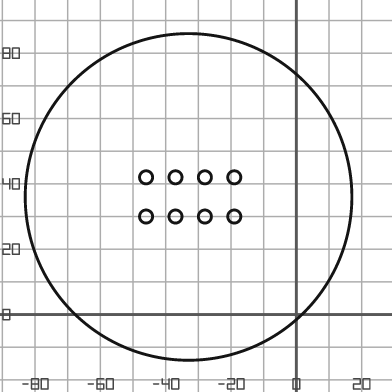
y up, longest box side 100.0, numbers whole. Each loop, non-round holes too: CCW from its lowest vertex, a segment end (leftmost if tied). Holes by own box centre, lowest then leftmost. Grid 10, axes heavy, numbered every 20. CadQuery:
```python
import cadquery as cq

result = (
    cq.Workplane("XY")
    .moveTo(-33.0, 36.0)
    .circle(50.0)
    .moveTo(-46.0, 30.0)
    .circle(2.0)
    .moveTo(-37.0, 30.0)
    .circle(2.0)
    .moveTo(-28.0, 30.0)
    .circle(2.0)
    .moveTo(-19.0, 30.0)
    .circle(2.0)
    .moveTo(-46.0, 42.0)
    .circle(2.0)
    .moveTo(-37.0, 42.0)
    .circle(2.0)
    .moveTo(-28.0, 42.0)
    .circle(2.0)
    .moveTo(-19.0, 42.0)
    .circle(2.0)
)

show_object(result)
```